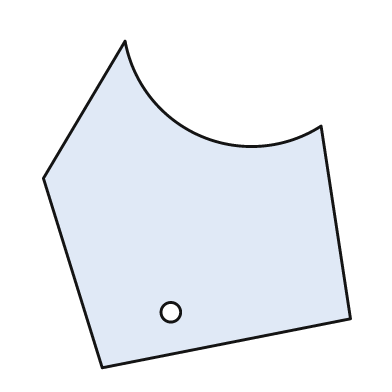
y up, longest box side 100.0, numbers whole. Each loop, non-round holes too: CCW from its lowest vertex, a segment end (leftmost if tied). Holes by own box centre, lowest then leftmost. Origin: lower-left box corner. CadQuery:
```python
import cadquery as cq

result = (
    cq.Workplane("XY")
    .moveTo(18.0, 0.0)
    .lineTo(94.0, 15.0)
    .lineTo(85.0, 74.0)
    .threePointArc((48.0, 71.0), (25.0, 100.0))
    .lineTo(0.0, 58.0)
    .close()
    .moveTo(39.0, 17.0)
    .circle(3.0)
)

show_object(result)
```